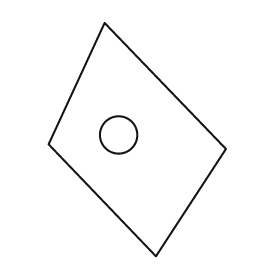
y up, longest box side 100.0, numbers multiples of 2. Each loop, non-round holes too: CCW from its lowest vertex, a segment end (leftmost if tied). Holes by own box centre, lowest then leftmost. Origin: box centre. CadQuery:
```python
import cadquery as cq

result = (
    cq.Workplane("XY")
    .moveTo(8.0, -50.0)
    .lineTo(38.0, -4.0)
    .lineTo(-14.0, 50.0)
    .lineTo(-38.0, -2.0)
    .close()
    .moveTo(-8.0, 2.0)
    .circle(8.0)
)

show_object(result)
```